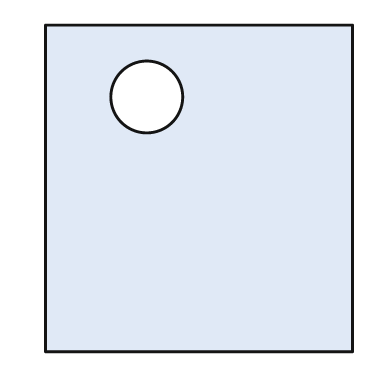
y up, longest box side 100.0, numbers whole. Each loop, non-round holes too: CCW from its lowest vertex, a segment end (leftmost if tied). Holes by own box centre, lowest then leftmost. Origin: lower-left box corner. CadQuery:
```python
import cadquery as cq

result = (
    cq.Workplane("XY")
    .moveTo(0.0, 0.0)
    .lineTo(94.0, 0.0)
    .lineTo(94.0, 100.0)
    .lineTo(0.0, 100.0)
    .close()
    .moveTo(31.0, 78.0)
    .circle(11.0)
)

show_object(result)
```